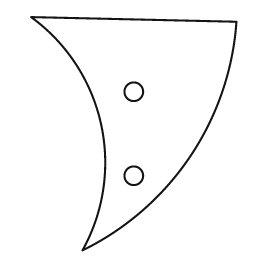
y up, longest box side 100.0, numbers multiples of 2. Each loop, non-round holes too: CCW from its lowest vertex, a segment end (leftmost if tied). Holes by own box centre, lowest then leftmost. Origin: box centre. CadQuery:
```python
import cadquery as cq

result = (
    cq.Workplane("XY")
    .moveTo(-22.0, -50.0)
    .threePointArc((24.0, -10.0), (44.0, 48.0))
    .lineTo(-44.0, 50.0)
    .threePointArc((-14.0, 4.0), (-22.0, -50.0))
    .close()
    .moveTo(0.0, -18.0)
    .circle(4.0)
    .moveTo(0.0, 18.0)
    .circle(4.0)
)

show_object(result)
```